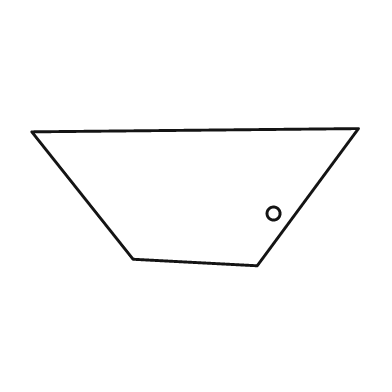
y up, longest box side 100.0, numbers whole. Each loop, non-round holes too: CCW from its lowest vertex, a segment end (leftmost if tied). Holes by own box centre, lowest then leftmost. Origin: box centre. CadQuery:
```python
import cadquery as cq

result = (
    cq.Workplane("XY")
    .moveTo(19.0, -21.0)
    .lineTo(50.0, 21.0)
    .lineTo(-50.0, 20.0)
    .lineTo(-19.0, -19.0)
    .close()
    .moveTo(24.0, -5.0)
    .circle(2.0)
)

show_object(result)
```